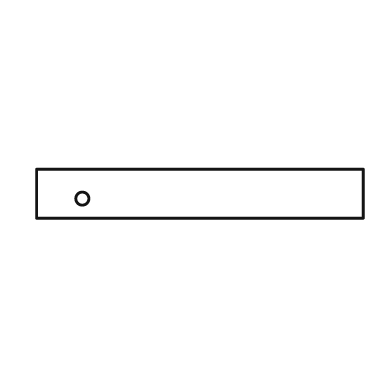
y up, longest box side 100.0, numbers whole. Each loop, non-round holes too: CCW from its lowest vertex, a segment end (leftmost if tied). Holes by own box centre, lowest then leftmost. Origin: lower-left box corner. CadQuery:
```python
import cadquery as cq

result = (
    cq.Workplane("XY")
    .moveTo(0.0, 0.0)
    .lineTo(100.0, 0.0)
    .lineTo(100.0, 15.0)
    .lineTo(0.0, 15.0)
    .close()
    .moveTo(14.0, 6.0)
    .circle(2.0)
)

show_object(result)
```